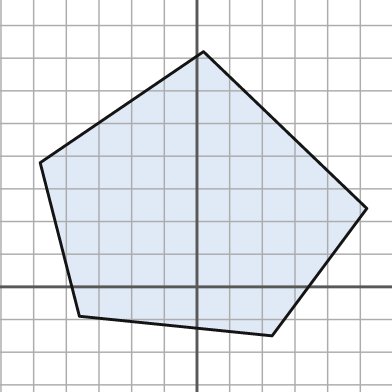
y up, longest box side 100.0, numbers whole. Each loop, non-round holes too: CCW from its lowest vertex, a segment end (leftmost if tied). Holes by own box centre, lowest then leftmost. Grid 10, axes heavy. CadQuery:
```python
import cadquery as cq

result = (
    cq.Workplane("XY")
    .moveTo(23.0, -15.0)
    .lineTo(52.0, 24.0)
    .lineTo(2.0, 72.0)
    .lineTo(-48.0, 38.0)
    .lineTo(-36.0, -9.0)
    .close()
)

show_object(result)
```